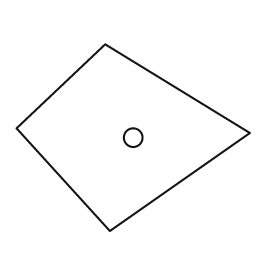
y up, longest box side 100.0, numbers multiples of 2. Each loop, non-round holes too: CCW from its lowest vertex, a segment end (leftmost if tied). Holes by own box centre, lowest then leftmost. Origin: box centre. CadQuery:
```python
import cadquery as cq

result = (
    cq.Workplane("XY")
    .moveTo(-10.0, -40.0)
    .lineTo(50.0, 2.0)
    .lineTo(-12.0, 40.0)
    .lineTo(-50.0, 4.0)
    .close()
    .moveTo(0.0, 0.0)
    .circle(4.0)
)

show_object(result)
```